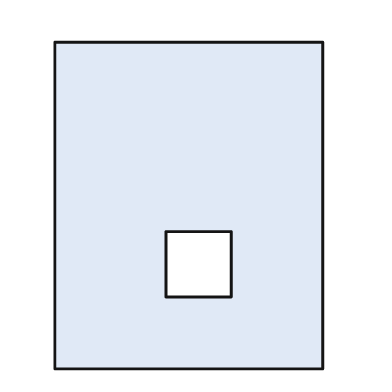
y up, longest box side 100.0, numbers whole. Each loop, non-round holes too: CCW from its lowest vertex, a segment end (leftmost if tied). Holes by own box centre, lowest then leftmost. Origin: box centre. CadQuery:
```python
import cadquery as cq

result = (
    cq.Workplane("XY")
    .moveTo(-41.0, -50.0)
    .lineTo(41.0, -50.0)
    .lineTo(41.0, 50.0)
    .lineTo(-41.0, 50.0)
    .close()
    .moveTo(-7.0, -28.0)
    .lineTo(13.0, -28.0)
    .lineTo(13.0, -8.0)
    .lineTo(-7.0, -8.0)
    .close()
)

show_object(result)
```